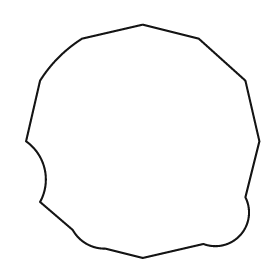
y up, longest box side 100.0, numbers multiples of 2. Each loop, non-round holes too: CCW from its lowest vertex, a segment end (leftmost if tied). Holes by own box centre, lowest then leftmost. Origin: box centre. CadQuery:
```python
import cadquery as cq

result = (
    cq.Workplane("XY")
    .moveTo(0.0, -50.0)
    .lineTo(26.0, -44.0)
    .threePointArc((42.0, -40.0), (44.0, -24.0))
    .lineTo(50.0, 0.0)
    .lineTo(44.0, 26.0)
    .lineTo(24.0, 44.0)
    .lineTo(0.0, 50.0)
    .lineTo(-26.0, 44.0)
    .threePointArc((-36.0, 36.0), (-44.0, 26.0))
    .lineTo(-50.0, 0.0)
    .threePointArc((-42.0, -12.0), (-44.0, -26.0))
    .lineTo(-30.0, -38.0)
    .threePointArc((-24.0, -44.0), (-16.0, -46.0))
    .close()
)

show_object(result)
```